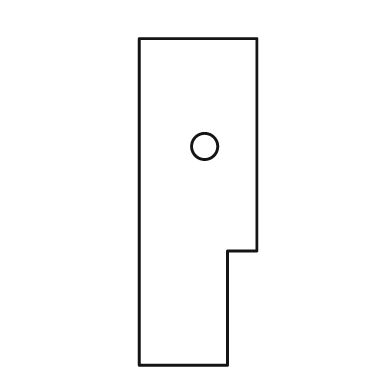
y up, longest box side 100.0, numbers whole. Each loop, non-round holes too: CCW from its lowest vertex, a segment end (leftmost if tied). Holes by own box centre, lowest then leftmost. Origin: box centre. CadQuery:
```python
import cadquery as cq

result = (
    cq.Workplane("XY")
    .moveTo(-18.0, -50.0)
    .lineTo(9.0, -50.0)
    .lineTo(9.0, -15.0)
    .lineTo(18.0, -15.0)
    .lineTo(18.0, 50.0)
    .lineTo(-18.0, 50.0)
    .close()
    .moveTo(2.0, 17.0)
    .circle(4.0)
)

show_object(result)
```